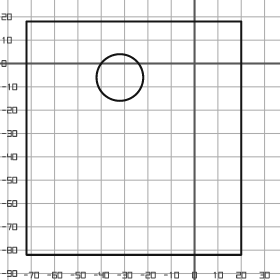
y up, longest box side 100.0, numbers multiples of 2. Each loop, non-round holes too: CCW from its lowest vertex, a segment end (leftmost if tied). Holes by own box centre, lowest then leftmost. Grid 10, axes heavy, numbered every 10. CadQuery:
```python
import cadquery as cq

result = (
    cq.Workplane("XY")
    .moveTo(-72.0, -82.0)
    .lineTo(20.0, -82.0)
    .lineTo(20.0, 18.0)
    .lineTo(-72.0, 18.0)
    .close()
    .moveTo(-32.0, -6.0)
    .circle(10.0)
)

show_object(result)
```